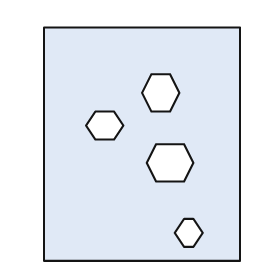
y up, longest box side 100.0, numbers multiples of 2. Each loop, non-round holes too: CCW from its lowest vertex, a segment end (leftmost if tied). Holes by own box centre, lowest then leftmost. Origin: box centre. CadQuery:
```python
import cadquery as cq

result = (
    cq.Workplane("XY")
    .moveTo(-42.0, -50.0)
    .lineTo(42.0, -50.0)
    .lineTo(42.0, 50.0)
    .lineTo(-42.0, 50.0)
    .close()
    .moveTo(18.0, -44.0)
    .lineTo(22.0, -44.0)
    .lineTo(26.0, -38.0)
    .lineTo(22.0, -32.0)
    .lineTo(18.0, -32.0)
    .lineTo(14.0, -38.0)
    .close()
    .moveTo(6.0, -16.0)
    .lineTo(18.0, -16.0)
    .lineTo(22.0, -8.0)
    .lineTo(18.0, 0.0)
    .lineTo(6.0, 0.0)
    .lineTo(2.0, -8.0)
    .close()
    .moveTo(-20.0, 2.0)
    .lineTo(-12.0, 2.0)
    .lineTo(-8.0, 8.0)
    .lineTo(-12.0, 14.0)
    .lineTo(-20.0, 14.0)
    .lineTo(-24.0, 8.0)
    .close()
    .moveTo(4.0, 14.0)
    .lineTo(12.0, 14.0)
    .lineTo(16.0, 22.0)
    .lineTo(12.0, 30.0)
    .lineTo(4.0, 30.0)
    .lineTo(0.0, 22.0)
    .close()
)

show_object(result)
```